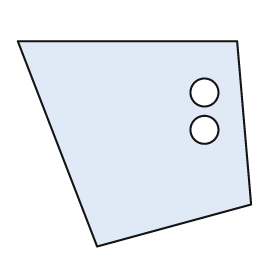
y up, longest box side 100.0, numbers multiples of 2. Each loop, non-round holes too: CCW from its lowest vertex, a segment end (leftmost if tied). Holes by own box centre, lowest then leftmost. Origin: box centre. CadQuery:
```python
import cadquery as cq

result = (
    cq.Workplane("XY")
    .moveTo(-16.0, -44.0)
    .lineTo(50.0, -26.0)
    .lineTo(44.0, 44.0)
    .lineTo(-50.0, 44.0)
    .close()
    .moveTo(30.0, 6.0)
    .circle(6.0)
    .moveTo(30.0, 22.0)
    .circle(6.0)
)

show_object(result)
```